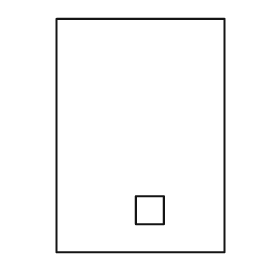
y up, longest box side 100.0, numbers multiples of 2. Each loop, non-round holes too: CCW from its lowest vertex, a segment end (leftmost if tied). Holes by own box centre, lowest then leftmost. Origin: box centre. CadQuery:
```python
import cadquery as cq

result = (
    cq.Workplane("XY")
    .moveTo(-36.0, -50.0)
    .lineTo(36.0, -50.0)
    .lineTo(36.0, 50.0)
    .lineTo(-36.0, 50.0)
    .close()
    .moveTo(-2.0, -38.0)
    .lineTo(10.0, -38.0)
    .lineTo(10.0, -26.0)
    .lineTo(-2.0, -26.0)
    .close()
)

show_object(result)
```